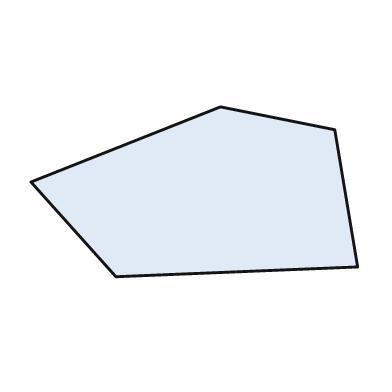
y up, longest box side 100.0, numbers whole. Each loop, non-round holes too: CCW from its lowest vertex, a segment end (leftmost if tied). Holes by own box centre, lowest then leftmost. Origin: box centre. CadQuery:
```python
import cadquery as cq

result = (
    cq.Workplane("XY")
    .moveTo(-24.0, -26.0)
    .lineTo(50.0, -23.0)
    .lineTo(43.0, 19.0)
    .lineTo(8.0, 26.0)
    .lineTo(-50.0, 3.0)
    .close()
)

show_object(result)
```